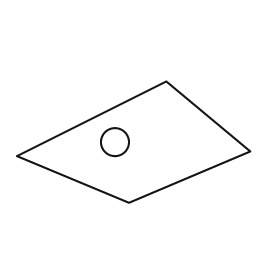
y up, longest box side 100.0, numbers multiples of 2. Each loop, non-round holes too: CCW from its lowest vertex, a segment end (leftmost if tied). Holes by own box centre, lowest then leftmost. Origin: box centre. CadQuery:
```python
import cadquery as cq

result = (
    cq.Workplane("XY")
    .moveTo(-2.0, -26.0)
    .lineTo(50.0, -4.0)
    .lineTo(14.0, 26.0)
    .lineTo(-50.0, -6.0)
    .close()
    .moveTo(-8.0, 0.0)
    .circle(6.0)
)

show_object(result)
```